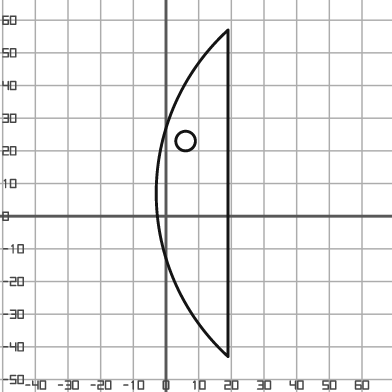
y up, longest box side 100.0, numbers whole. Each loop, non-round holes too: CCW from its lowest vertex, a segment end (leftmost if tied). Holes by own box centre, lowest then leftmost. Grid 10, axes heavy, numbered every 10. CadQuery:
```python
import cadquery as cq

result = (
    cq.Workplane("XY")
    .moveTo(19.0, -43.0)
    .lineTo(19.0, 57.0)
    .threePointArc((-3.0, 7.0), (19.0, -43.0))
    .close()
    .moveTo(6.0, 23.0)
    .circle(3.0)
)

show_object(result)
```